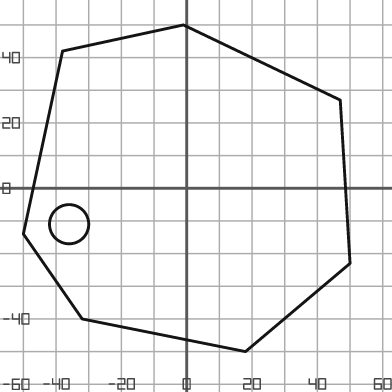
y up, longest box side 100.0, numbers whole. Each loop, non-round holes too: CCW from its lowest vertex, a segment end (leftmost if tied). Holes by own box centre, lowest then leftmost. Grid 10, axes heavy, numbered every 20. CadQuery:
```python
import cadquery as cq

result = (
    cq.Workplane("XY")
    .moveTo(18.0, -50.0)
    .lineTo(50.0, -23.0)
    .lineTo(47.0, 27.0)
    .lineTo(-1.0, 50.0)
    .lineTo(-38.0, 42.0)
    .lineTo(-50.0, -14.0)
    .lineTo(-32.0, -40.0)
    .close()
    .moveTo(-36.0, -11.0)
    .circle(6.0)
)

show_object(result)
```